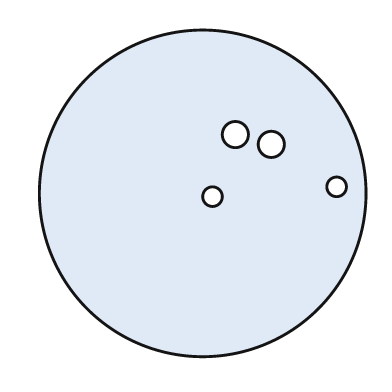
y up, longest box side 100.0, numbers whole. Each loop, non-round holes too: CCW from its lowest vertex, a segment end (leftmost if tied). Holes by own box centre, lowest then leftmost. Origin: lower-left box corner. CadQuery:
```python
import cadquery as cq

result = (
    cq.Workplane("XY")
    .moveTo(50.0, 50.0)
    .circle(50.0)
    .moveTo(53.0, 49.0)
    .circle(3.0)
    .moveTo(91.0, 52.0)
    .circle(3.0)
    .moveTo(71.0, 65.0)
    .circle(4.0)
    .moveTo(60.0, 68.0)
    .circle(4.0)
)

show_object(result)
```